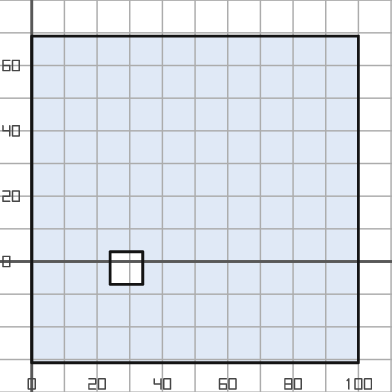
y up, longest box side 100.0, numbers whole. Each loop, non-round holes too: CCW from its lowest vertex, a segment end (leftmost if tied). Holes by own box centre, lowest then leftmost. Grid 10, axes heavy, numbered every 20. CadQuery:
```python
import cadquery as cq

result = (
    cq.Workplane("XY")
    .moveTo(0.0, -31.0)
    .lineTo(100.0, -31.0)
    .lineTo(100.0, 69.0)
    .lineTo(0.0, 69.0)
    .close()
    .moveTo(24.0, -7.0)
    .lineTo(34.0, -7.0)
    .lineTo(34.0, 3.0)
    .lineTo(24.0, 3.0)
    .close()
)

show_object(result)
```